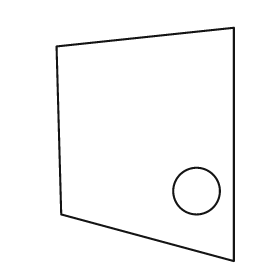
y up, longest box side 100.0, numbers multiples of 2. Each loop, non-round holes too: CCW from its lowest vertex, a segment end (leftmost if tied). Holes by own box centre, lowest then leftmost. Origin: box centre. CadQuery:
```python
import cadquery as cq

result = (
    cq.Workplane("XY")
    .moveTo(38.0, -50.0)
    .lineTo(38.0, 50.0)
    .lineTo(-38.0, 42.0)
    .lineTo(-36.0, -30.0)
    .close()
    .moveTo(22.0, -20.0)
    .circle(10.0)
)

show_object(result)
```